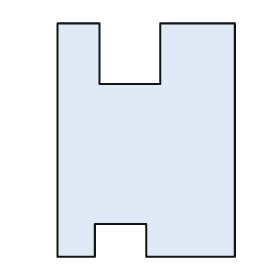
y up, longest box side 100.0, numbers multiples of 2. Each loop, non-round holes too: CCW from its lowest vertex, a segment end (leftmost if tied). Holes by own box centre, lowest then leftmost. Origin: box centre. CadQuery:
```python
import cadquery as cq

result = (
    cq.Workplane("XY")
    .moveTo(-38.0, -50.0)
    .lineTo(-22.0, -50.0)
    .lineTo(-22.0, -36.0)
    .lineTo(0.0, -36.0)
    .lineTo(0.0, -50.0)
    .lineTo(38.0, -50.0)
    .lineTo(38.0, 50.0)
    .lineTo(6.0, 50.0)
    .lineTo(6.0, 24.0)
    .lineTo(-20.0, 24.0)
    .lineTo(-20.0, 50.0)
    .lineTo(-38.0, 50.0)
    .close()
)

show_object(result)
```